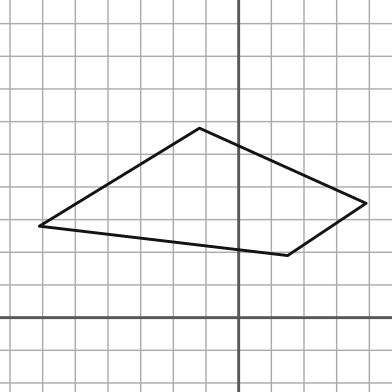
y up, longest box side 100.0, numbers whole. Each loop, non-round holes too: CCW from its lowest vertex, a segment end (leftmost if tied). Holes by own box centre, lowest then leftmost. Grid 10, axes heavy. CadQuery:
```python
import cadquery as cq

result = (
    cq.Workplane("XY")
    .moveTo(15.0, 19.0)
    .lineTo(39.0, 35.0)
    .lineTo(-12.0, 58.0)
    .lineTo(-61.0, 28.0)
    .close()
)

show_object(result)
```